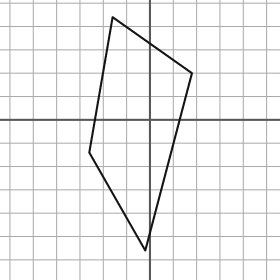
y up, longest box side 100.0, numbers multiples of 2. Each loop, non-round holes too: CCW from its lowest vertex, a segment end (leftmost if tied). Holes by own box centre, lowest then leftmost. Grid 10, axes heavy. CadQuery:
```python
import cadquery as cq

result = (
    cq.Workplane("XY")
    .moveTo(-2.0, -56.0)
    .lineTo(18.0, 20.0)
    .lineTo(-16.0, 44.0)
    .lineTo(-26.0, -14.0)
    .close()
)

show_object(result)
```